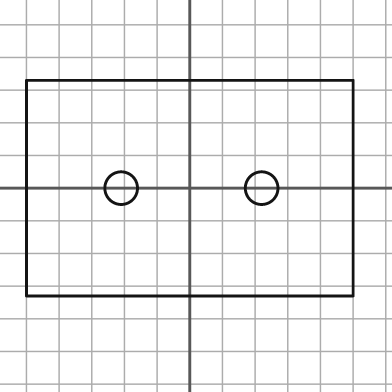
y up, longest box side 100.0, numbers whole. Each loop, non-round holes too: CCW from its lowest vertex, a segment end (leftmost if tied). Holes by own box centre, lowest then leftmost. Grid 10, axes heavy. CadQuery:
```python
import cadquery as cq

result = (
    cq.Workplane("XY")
    .moveTo(-50.0, -33.0)
    .lineTo(50.0, -33.0)
    .lineTo(50.0, 33.0)
    .lineTo(-50.0, 33.0)
    .close()
    .moveTo(-21.0, 0.0)
    .circle(5.0)
    .moveTo(22.0, 0.0)
    .circle(5.0)
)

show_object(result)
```